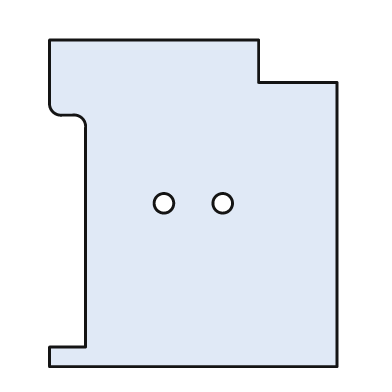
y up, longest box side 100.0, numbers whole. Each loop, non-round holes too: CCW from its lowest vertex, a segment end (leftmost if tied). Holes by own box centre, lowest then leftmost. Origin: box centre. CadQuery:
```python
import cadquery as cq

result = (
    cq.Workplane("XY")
    .moveTo(-44.0, -50.0)
    .lineTo(44.0, -50.0)
    .lineTo(44.0, 37.0)
    .lineTo(20.0, 37.0)
    .lineTo(20.0, 50.0)
    .lineTo(-44.0, 50.0)
    .lineTo(-44.0, 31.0)
    .threePointArc((-43.0, 28.0), (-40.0, 27.0))
    .lineTo(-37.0, 27.0)
    .threePointArc((-34.0, 26.0), (-33.0, 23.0))
    .lineTo(-33.0, -44.0)
    .lineTo(-44.0, -44.0)
    .close()
    .moveTo(-9.0, 0.0)
    .circle(3.0)
    .moveTo(9.0, 0.0)
    .circle(3.0)
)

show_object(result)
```